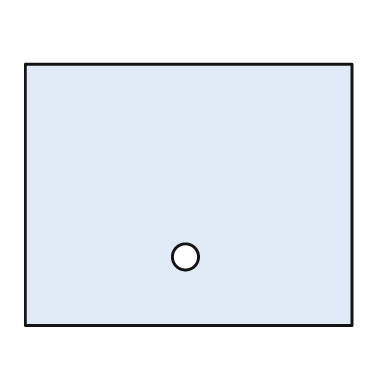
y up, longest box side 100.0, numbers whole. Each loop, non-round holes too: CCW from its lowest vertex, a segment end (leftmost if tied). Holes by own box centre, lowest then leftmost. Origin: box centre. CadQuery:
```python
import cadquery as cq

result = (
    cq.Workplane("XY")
    .moveTo(-50.0, -40.0)
    .lineTo(50.0, -40.0)
    .lineTo(50.0, 40.0)
    .lineTo(-50.0, 40.0)
    .close()
    .moveTo(-1.0, -19.0)
    .circle(4.0)
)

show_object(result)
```